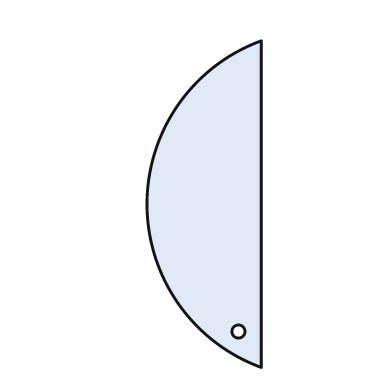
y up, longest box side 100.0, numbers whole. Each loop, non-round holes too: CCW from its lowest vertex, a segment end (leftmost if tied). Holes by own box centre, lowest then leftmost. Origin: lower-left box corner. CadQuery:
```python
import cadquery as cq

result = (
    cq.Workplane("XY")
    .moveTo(35.0, 0.0)
    .lineTo(35.0, 100.0)
    .threePointArc((0.0, 50.0), (35.0, 0.0))
    .close()
    .moveTo(28.0, 11.0)
    .circle(2.0)
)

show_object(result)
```